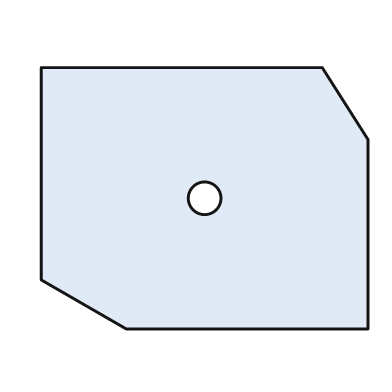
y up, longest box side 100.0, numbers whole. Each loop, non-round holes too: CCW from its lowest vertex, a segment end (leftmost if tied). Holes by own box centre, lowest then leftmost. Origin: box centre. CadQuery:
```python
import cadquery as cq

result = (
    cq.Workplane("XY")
    .moveTo(-24.0, -40.0)
    .lineTo(50.0, -40.0)
    .lineTo(50.0, 18.0)
    .lineTo(36.0, 40.0)
    .lineTo(-50.0, 40.0)
    .lineTo(-50.0, -25.0)
    .close()
    .moveTo(0.0, 0.0)
    .circle(5.0)
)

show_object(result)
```